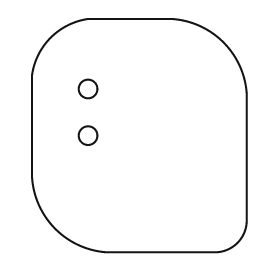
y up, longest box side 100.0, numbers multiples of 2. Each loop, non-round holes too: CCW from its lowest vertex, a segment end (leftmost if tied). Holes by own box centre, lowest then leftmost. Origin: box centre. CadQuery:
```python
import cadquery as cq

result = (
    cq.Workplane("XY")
    .moveTo(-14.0, -50.0)
    .lineTo(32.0, -50.0)
    .threePointArc((42.0, -46.0), (46.0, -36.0))
    .lineTo(46.0, 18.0)
    .threePointArc((36.0, 40.0), (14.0, 50.0))
    .lineTo(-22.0, 50.0)
    .threePointArc((-38.0, 42.0), (-46.0, 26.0))
    .lineTo(-46.0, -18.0)
    .threePointArc((-36.0, -40.0), (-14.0, -50.0))
    .close()
    .moveTo(-22.0, 0.0)
    .circle(4.0)
    .moveTo(-22.0, 20.0)
    .circle(4.0)
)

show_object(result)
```